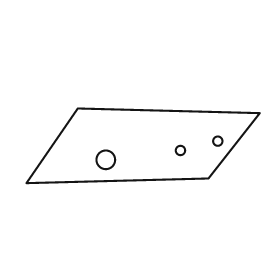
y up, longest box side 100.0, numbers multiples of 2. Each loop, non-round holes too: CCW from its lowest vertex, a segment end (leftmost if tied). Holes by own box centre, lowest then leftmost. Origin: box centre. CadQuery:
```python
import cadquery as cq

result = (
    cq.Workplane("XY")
    .moveTo(-50.0, -16.0)
    .lineTo(28.0, -14.0)
    .lineTo(50.0, 14.0)
    .lineTo(-28.0, 16.0)
    .close()
    .moveTo(-16.0, -6.0)
    .circle(4.0)
    .moveTo(16.0, -2.0)
    .circle(2.0)
    .moveTo(32.0, 2.0)
    .circle(2.0)
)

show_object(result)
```